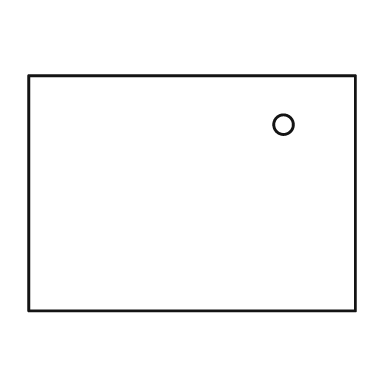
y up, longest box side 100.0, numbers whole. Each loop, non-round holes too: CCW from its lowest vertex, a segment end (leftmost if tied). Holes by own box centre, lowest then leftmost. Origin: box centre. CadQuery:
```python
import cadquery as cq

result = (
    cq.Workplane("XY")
    .moveTo(-50.0, -36.0)
    .lineTo(50.0, -36.0)
    .lineTo(50.0, 36.0)
    .lineTo(-50.0, 36.0)
    .close()
    .moveTo(28.0, 21.0)
    .circle(3.0)
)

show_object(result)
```